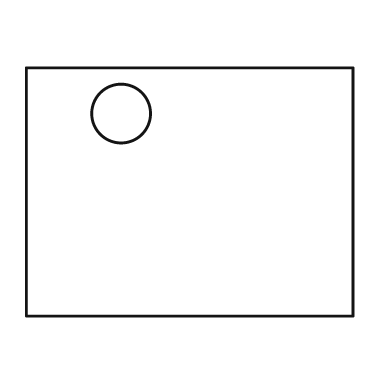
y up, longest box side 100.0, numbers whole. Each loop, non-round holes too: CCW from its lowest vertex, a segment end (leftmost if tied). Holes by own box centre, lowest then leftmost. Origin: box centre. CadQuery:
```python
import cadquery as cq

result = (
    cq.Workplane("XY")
    .moveTo(-50.0, -38.0)
    .lineTo(50.0, -38.0)
    .lineTo(50.0, 38.0)
    .lineTo(-50.0, 38.0)
    .close()
    .moveTo(-21.0, 24.0)
    .circle(9.0)
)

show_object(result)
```